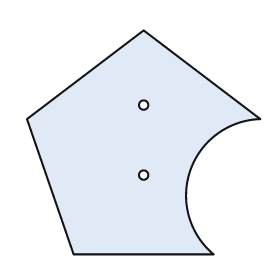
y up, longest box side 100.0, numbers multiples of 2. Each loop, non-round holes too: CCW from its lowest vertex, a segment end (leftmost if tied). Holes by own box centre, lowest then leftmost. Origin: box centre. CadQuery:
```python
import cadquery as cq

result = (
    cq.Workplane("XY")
    .moveTo(-30.0, -48.0)
    .lineTo(30.0, -48.0)
    .threePointArc((20.0, -12.0), (50.0, 10.0))
    .lineTo(0.0, 48.0)
    .lineTo(-50.0, 10.0)
    .close()
    .moveTo(0.0, -14.0)
    .circle(2.0)
    .moveTo(0.0, 16.0)
    .circle(2.0)
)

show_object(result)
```